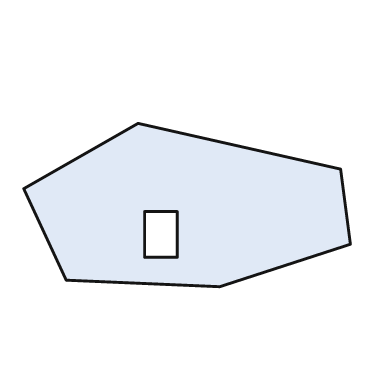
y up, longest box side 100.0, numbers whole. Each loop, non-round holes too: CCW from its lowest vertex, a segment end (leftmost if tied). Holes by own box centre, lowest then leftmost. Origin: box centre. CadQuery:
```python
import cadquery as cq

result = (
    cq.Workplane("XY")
    .moveTo(10.0, -25.0)
    .lineTo(50.0, -12.0)
    .lineTo(47.0, 11.0)
    .lineTo(-15.0, 25.0)
    .lineTo(-50.0, 5.0)
    .lineTo(-37.0, -23.0)
    .close()
    .moveTo(-13.0, -16.0)
    .lineTo(-3.0, -16.0)
    .lineTo(-3.0, -2.0)
    .lineTo(-13.0, -2.0)
    .close()
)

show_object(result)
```